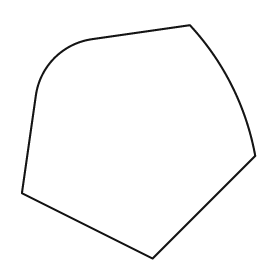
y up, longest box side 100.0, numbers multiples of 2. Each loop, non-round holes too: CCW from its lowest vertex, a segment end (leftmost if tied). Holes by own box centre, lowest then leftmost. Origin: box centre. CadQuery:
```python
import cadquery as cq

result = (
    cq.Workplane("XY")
    .moveTo(6.0, -50.0)
    .lineTo(50.0, -6.0)
    .threePointArc((40.0, 24.0), (22.0, 50.0))
    .lineTo(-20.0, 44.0)
    .threePointArc((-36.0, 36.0), (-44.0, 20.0))
    .lineTo(-50.0, -22.0)
    .close()
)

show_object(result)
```